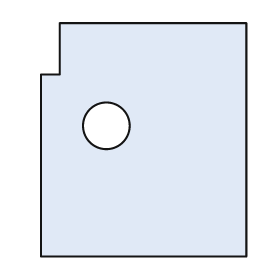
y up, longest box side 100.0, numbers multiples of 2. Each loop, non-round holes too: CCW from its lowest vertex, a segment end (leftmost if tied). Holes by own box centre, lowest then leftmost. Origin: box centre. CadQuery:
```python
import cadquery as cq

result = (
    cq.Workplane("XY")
    .moveTo(-44.0, -50.0)
    .lineTo(44.0, -50.0)
    .lineTo(44.0, 50.0)
    .lineTo(-36.0, 50.0)
    .lineTo(-36.0, 28.0)
    .lineTo(-44.0, 28.0)
    .close()
    .moveTo(-16.0, 6.0)
    .circle(10.0)
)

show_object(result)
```